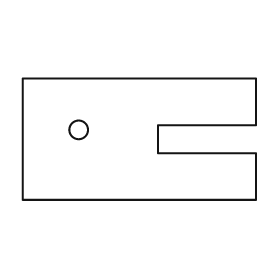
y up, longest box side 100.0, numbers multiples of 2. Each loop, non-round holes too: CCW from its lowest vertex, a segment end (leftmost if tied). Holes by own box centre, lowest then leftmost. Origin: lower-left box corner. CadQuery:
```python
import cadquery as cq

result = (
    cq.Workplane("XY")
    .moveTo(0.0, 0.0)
    .lineTo(100.0, 0.0)
    .lineTo(100.0, 20.0)
    .lineTo(58.0, 20.0)
    .lineTo(58.0, 32.0)
    .lineTo(100.0, 32.0)
    .lineTo(100.0, 52.0)
    .lineTo(0.0, 52.0)
    .close()
    .moveTo(24.0, 30.0)
    .circle(4.0)
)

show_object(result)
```